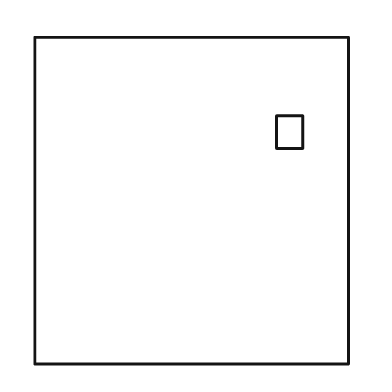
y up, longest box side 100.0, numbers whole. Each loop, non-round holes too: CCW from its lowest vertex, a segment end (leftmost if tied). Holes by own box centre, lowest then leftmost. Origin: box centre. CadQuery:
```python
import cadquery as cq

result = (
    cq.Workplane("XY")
    .moveTo(-48.0, -50.0)
    .lineTo(48.0, -50.0)
    .lineTo(48.0, 50.0)
    .lineTo(-48.0, 50.0)
    .close()
    .moveTo(26.0, 16.0)
    .lineTo(34.0, 16.0)
    .lineTo(34.0, 26.0)
    .lineTo(26.0, 26.0)
    .close()
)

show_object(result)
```